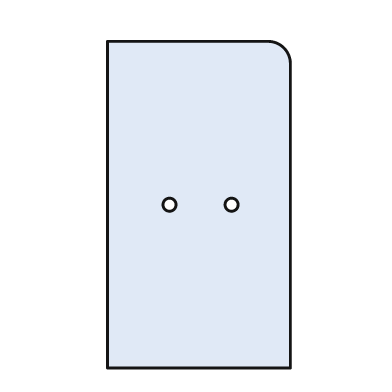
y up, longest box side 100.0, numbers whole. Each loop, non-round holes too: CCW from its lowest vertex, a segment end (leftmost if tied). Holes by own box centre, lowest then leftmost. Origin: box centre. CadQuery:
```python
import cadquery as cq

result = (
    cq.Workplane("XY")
    .moveTo(-28.0, -50.0)
    .lineTo(28.0, -50.0)
    .lineTo(28.0, 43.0)
    .threePointArc((26.0, 48.0), (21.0, 50.0))
    .lineTo(-28.0, 50.0)
    .close()
    .moveTo(-9.0, 0.0)
    .circle(2.0)
    .moveTo(10.0, 0.0)
    .circle(2.0)
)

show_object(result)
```